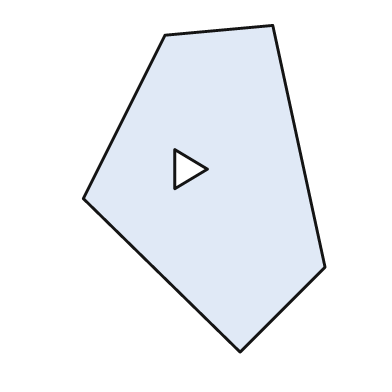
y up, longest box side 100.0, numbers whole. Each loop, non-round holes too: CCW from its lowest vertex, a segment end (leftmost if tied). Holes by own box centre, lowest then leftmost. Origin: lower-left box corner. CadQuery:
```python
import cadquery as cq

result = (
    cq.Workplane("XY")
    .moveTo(48.0, 0.0)
    .lineTo(74.0, 26.0)
    .lineTo(58.0, 100.0)
    .lineTo(25.0, 97.0)
    .lineTo(0.0, 47.0)
    .close()
    .moveTo(28.0, 50.0)
    .lineTo(38.0, 56.0)
    .lineTo(28.0, 62.0)
    .close()
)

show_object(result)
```